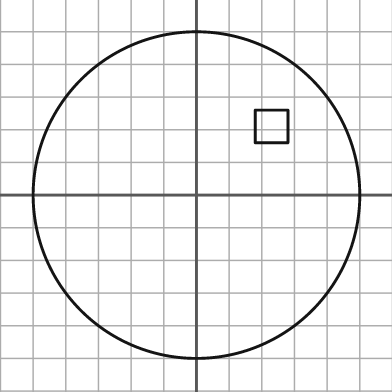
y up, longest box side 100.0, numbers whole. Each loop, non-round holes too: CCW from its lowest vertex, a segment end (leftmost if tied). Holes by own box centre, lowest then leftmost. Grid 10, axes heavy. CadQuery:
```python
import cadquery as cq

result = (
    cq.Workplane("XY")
    .moveTo(0.0, 0.0)
    .circle(50.0)
    .moveTo(18.0, 16.0)
    .lineTo(28.0, 16.0)
    .lineTo(28.0, 26.0)
    .lineTo(18.0, 26.0)
    .close()
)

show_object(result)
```